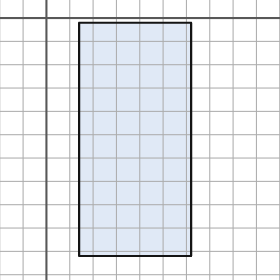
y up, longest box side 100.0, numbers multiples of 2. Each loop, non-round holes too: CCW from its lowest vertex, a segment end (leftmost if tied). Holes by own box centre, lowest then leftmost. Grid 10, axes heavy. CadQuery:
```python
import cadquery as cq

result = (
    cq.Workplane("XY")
    .moveTo(14.0, -102.0)
    .lineTo(62.0, -102.0)
    .lineTo(62.0, -2.0)
    .lineTo(14.0, -2.0)
    .close()
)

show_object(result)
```